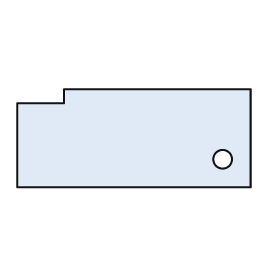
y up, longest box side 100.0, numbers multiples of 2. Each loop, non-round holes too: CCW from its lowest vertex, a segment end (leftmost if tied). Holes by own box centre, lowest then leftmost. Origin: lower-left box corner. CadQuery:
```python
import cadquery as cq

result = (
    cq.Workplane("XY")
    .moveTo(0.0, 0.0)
    .lineTo(100.0, 0.0)
    .lineTo(100.0, 42.0)
    .lineTo(20.0, 42.0)
    .lineTo(20.0, 36.0)
    .lineTo(0.0, 36.0)
    .close()
    .moveTo(88.0, 12.0)
    .circle(4.0)
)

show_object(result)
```